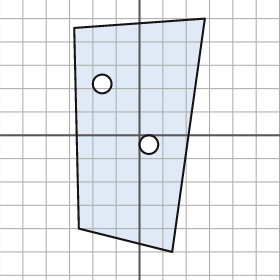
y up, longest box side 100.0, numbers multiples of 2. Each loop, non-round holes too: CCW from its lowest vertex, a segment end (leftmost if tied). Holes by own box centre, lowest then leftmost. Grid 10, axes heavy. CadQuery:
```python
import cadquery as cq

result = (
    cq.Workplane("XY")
    .moveTo(14.0, -50.0)
    .lineTo(28.0, 50.0)
    .lineTo(-28.0, 46.0)
    .lineTo(-26.0, -40.0)
    .close()
    .moveTo(4.0, -4.0)
    .circle(4.0)
    .moveTo(-16.0, 22.0)
    .circle(4.0)
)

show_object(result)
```